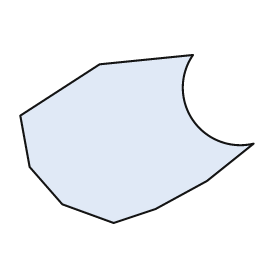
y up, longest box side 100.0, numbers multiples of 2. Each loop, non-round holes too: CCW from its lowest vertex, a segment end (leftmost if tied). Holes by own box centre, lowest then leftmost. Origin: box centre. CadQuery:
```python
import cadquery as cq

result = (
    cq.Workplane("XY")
    .moveTo(-10.0, -36.0)
    .lineTo(8.0, -30.0)
    .lineTo(30.0, -18.0)
    .lineTo(50.0, -2.0)
    .threePointArc((24.0, 8.0), (24.0, 36.0))
    .lineTo(-16.0, 32.0)
    .lineTo(-50.0, 10.0)
    .lineTo(-46.0, -12.0)
    .lineTo(-32.0, -28.0)
    .close()
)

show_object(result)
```